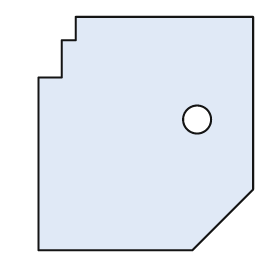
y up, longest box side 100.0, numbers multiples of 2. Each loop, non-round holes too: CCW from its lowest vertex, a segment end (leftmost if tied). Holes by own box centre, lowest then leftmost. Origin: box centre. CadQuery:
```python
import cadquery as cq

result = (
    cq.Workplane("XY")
    .moveTo(-46.0, -50.0)
    .lineTo(20.0, -50.0)
    .lineTo(46.0, -24.0)
    .lineTo(46.0, 50.0)
    .lineTo(-30.0, 50.0)
    .lineTo(-30.0, 40.0)
    .lineTo(-36.0, 40.0)
    .lineTo(-36.0, 24.0)
    .lineTo(-46.0, 24.0)
    .close()
    .moveTo(22.0, 6.0)
    .circle(6.0)
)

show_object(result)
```